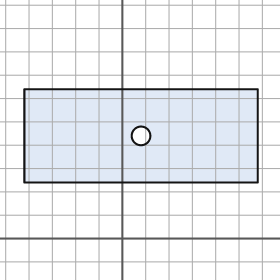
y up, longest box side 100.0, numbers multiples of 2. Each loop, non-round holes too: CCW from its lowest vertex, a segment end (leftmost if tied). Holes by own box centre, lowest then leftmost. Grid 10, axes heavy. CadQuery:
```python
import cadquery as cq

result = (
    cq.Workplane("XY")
    .moveTo(-42.0, 24.0)
    .lineTo(58.0, 24.0)
    .lineTo(58.0, 64.0)
    .lineTo(-42.0, 64.0)
    .close()
    .moveTo(8.0, 44.0)
    .circle(4.0)
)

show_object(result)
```